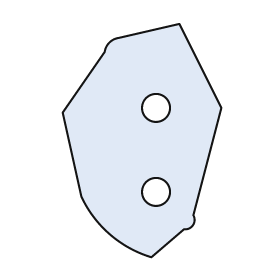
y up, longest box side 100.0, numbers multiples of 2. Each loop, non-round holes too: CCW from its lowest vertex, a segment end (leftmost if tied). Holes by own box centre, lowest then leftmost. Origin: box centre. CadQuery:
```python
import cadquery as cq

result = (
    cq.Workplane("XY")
    .moveTo(4.0, -50.0)
    .lineTo(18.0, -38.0)
    .threePointArc((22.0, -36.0), (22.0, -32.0))
    .lineTo(34.0, 14.0)
    .lineTo(16.0, 50.0)
    .lineTo(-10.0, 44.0)
    .threePointArc((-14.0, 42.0), (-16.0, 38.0))
    .lineTo(-34.0, 12.0)
    .lineTo(-26.0, -24.0)
    .threePointArc((-14.0, -40.0), (4.0, -50.0))
    .close()
    .moveTo(6.0, -22.0)
    .circle(6.0)
    .moveTo(6.0, 14.0)
    .circle(6.0)
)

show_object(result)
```